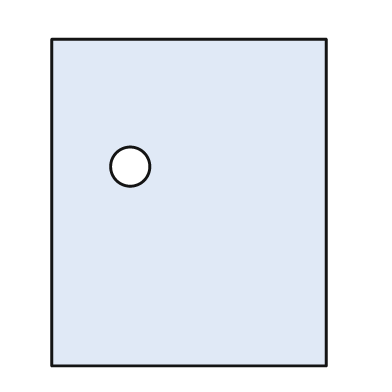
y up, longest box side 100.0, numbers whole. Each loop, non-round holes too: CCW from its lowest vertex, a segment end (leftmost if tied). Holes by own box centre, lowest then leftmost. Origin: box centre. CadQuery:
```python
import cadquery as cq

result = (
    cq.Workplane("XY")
    .moveTo(-42.0, -50.0)
    .lineTo(42.0, -50.0)
    .lineTo(42.0, 50.0)
    .lineTo(-42.0, 50.0)
    .close()
    .moveTo(-18.0, 11.0)
    .circle(6.0)
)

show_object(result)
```